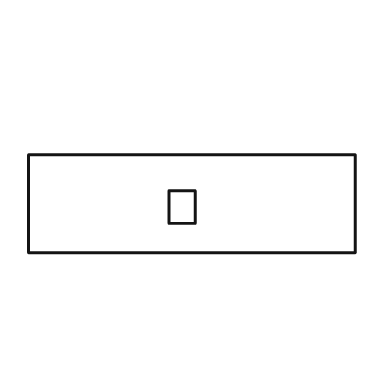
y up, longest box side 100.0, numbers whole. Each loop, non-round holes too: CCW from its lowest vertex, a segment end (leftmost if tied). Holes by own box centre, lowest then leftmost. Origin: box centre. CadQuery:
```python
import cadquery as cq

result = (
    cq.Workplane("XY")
    .moveTo(-50.0, -15.0)
    .lineTo(50.0, -15.0)
    .lineTo(50.0, 15.0)
    .lineTo(-50.0, 15.0)
    .close()
    .moveTo(-7.0, -6.0)
    .lineTo(1.0, -6.0)
    .lineTo(1.0, 4.0)
    .lineTo(-7.0, 4.0)
    .close()
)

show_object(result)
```